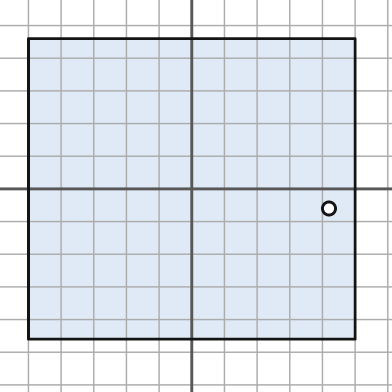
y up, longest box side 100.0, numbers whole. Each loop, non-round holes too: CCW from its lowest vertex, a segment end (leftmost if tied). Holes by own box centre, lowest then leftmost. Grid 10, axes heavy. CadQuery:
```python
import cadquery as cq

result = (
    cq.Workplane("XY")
    .moveTo(-50.0, -46.0)
    .lineTo(50.0, -46.0)
    .lineTo(50.0, 46.0)
    .lineTo(-50.0, 46.0)
    .close()
    .moveTo(42.0, -6.0)
    .circle(2.0)
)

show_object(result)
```